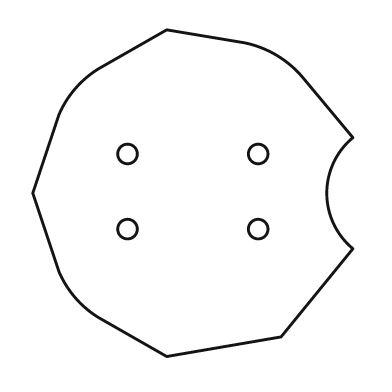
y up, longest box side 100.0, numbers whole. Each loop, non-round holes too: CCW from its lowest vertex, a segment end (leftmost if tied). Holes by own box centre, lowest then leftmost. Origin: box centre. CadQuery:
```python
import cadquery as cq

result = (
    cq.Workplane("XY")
    .moveTo(-8.0, -50.0)
    .lineTo(27.0, -44.0)
    .lineTo(49.0, -17.0)
    .threePointArc((41.0, 0.0), (49.0, 17.0))
    .lineTo(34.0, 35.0)
    .threePointArc((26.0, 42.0), (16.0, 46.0))
    .lineTo(-8.0, 50.0)
    .lineTo(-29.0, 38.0)
    .threePointArc((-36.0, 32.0), (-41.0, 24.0))
    .lineTo(-49.0, 0.0)
    .lineTo(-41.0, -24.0)
    .threePointArc((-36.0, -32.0), (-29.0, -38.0))
    .close()
    .moveTo(-20.0, -11.0)
    .circle(3.0)
    .moveTo(20.0, -11.0)
    .circle(3.0)
    .moveTo(-20.0, 12.0)
    .circle(3.0)
    .moveTo(20.0, 12.0)
    .circle(3.0)
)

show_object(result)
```